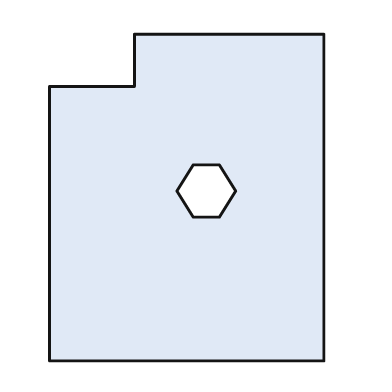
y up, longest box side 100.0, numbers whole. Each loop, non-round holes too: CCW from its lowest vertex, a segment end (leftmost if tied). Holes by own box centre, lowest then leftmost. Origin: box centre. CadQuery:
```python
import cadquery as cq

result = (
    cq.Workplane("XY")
    .moveTo(-42.0, -50.0)
    .lineTo(42.0, -50.0)
    .lineTo(42.0, 50.0)
    .lineTo(-16.0, 50.0)
    .lineTo(-16.0, 34.0)
    .lineTo(-42.0, 34.0)
    .close()
    .moveTo(2.0, -6.0)
    .lineTo(10.0, -6.0)
    .lineTo(15.0, 2.0)
    .lineTo(10.0, 10.0)
    .lineTo(2.0, 10.0)
    .lineTo(-3.0, 2.0)
    .close()
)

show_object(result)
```